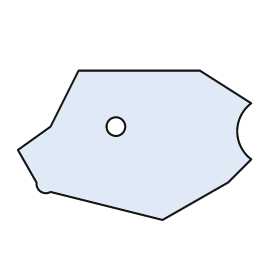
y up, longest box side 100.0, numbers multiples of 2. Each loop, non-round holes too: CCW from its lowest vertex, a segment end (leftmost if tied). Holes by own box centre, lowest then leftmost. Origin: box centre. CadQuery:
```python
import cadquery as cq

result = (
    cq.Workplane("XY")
    .moveTo(12.0, -32.0)
    .lineTo(40.0, -16.0)
    .lineTo(50.0, -6.0)
    .threePointArc((44.0, 6.0), (50.0, 18.0))
    .lineTo(28.0, 32.0)
    .lineTo(-24.0, 32.0)
    .lineTo(-36.0, 8.0)
    .lineTo(-50.0, -2.0)
    .lineTo(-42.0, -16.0)
    .threePointArc((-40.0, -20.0), (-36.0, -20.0))
    .close()
    .moveTo(-8.0, 8.0)
    .circle(4.0)
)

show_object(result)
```